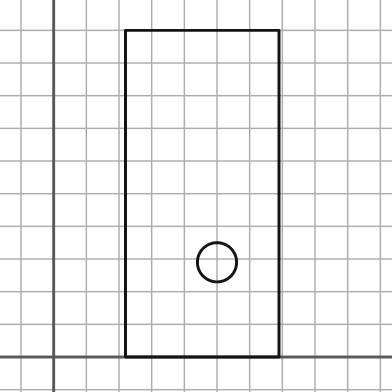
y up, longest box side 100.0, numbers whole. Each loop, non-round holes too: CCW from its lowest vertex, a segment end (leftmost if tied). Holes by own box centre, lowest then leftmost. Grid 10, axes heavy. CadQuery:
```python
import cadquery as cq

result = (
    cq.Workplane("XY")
    .moveTo(22.0, 0.0)
    .lineTo(69.0, 0.0)
    .lineTo(69.0, 100.0)
    .lineTo(22.0, 100.0)
    .close()
    .moveTo(50.0, 29.0)
    .circle(6.0)
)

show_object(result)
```